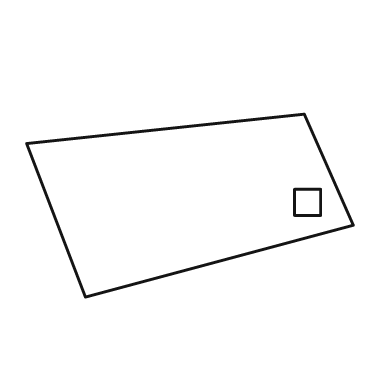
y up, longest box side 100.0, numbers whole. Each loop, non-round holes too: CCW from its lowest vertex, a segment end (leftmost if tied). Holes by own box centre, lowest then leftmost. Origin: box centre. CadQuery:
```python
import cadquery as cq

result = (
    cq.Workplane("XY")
    .moveTo(-32.0, -28.0)
    .lineTo(50.0, -6.0)
    .lineTo(35.0, 28.0)
    .lineTo(-50.0, 19.0)
    .close()
    .moveTo(32.0, -3.0)
    .lineTo(40.0, -3.0)
    .lineTo(40.0, 5.0)
    .lineTo(32.0, 5.0)
    .close()
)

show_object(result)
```